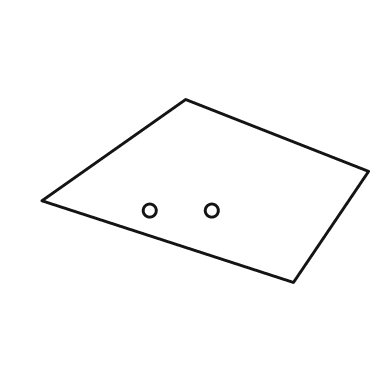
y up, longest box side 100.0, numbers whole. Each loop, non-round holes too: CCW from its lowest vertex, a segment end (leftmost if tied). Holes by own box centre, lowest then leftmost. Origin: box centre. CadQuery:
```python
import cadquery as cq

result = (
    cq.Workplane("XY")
    .moveTo(27.0, -28.0)
    .lineTo(50.0, 6.0)
    .lineTo(-6.0, 28.0)
    .lineTo(-50.0, -3.0)
    .close()
    .moveTo(-17.0, -6.0)
    .circle(2.0)
    .moveTo(2.0, -6.0)
    .circle(2.0)
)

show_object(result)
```